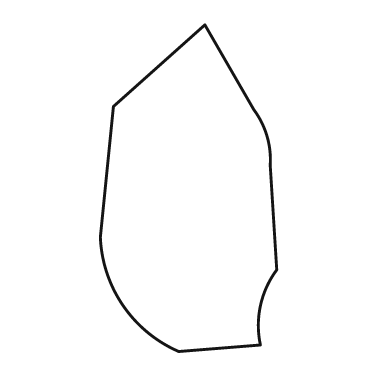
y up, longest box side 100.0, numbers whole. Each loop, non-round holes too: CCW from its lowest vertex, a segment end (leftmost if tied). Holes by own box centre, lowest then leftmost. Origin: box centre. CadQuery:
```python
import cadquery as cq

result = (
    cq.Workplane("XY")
    .moveTo(-3.0, -50.0)
    .lineTo(22.0, -48.0)
    .threePointArc((22.0, -36.0), (27.0, -25.0))
    .lineTo(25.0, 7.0)
    .threePointArc((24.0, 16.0), (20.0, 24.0))
    .lineTo(5.0, 50.0)
    .lineTo(-23.0, 25.0)
    .lineTo(-27.0, -15.0)
    .threePointArc((-20.0, -36.0), (-3.0, -50.0))
    .close()
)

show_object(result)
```